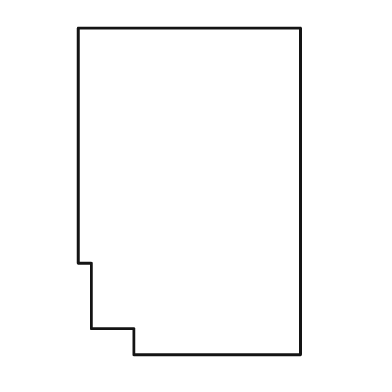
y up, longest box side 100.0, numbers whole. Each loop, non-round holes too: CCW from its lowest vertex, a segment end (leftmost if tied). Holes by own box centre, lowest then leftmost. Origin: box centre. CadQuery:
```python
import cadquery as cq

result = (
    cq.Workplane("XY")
    .moveTo(-17.0, -50.0)
    .lineTo(34.0, -50.0)
    .lineTo(34.0, 50.0)
    .lineTo(-34.0, 50.0)
    .lineTo(-34.0, -22.0)
    .lineTo(-30.0, -22.0)
    .lineTo(-30.0, -42.0)
    .lineTo(-17.0, -42.0)
    .close()
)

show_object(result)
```